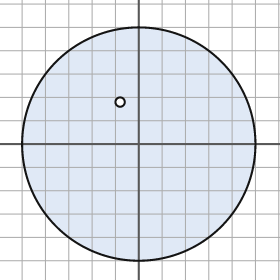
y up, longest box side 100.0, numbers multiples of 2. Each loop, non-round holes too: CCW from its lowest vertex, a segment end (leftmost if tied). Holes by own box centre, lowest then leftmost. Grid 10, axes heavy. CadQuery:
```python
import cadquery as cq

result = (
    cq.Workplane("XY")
    .moveTo(0.0, 0.0)
    .circle(50.0)
    .moveTo(-8.0, 18.0)
    .circle(2.0)
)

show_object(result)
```